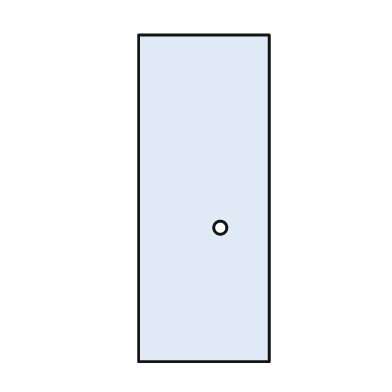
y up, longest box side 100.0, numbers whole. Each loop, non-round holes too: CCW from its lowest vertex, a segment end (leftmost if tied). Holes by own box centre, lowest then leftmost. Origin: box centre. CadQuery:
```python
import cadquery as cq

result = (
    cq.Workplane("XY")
    .moveTo(-20.0, -50.0)
    .lineTo(20.0, -50.0)
    .lineTo(20.0, 50.0)
    .lineTo(-20.0, 50.0)
    .close()
    .moveTo(5.0, -9.0)
    .circle(2.0)
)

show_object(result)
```